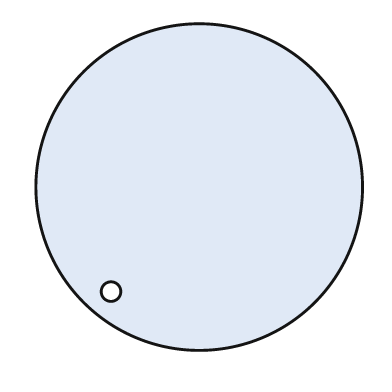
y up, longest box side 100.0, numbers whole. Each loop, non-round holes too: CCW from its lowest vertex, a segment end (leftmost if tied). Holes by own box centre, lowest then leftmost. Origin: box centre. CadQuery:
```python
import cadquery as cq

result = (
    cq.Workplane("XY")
    .moveTo(0.0, 0.0)
    .circle(50.0)
    .moveTo(-27.0, -32.0)
    .circle(3.0)
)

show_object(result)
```